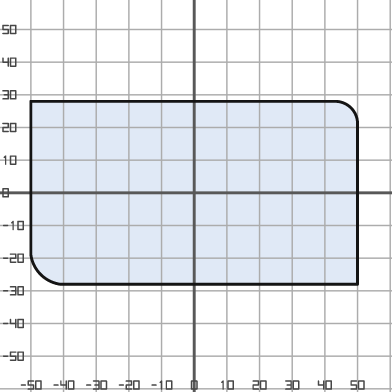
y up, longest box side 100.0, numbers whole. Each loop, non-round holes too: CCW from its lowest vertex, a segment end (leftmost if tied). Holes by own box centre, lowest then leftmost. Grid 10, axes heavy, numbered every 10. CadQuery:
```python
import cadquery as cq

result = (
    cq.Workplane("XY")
    .moveTo(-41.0, -28.0)
    .lineTo(50.0, -28.0)
    .lineTo(50.0, 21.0)
    .threePointArc((48.0, 26.0), (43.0, 28.0))
    .lineTo(-50.0, 28.0)
    .lineTo(-50.0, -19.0)
    .threePointArc((-47.0, -25.0), (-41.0, -28.0))
    .close()
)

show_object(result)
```